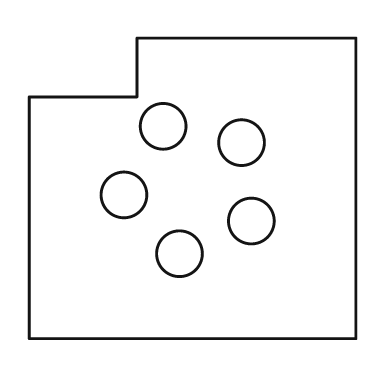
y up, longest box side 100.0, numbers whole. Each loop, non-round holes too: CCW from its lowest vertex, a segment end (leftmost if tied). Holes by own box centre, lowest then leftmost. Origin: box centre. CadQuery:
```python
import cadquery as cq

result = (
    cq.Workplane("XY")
    .moveTo(-50.0, -46.0)
    .lineTo(50.0, -46.0)
    .lineTo(50.0, 46.0)
    .lineTo(-17.0, 46.0)
    .lineTo(-17.0, 28.0)
    .lineTo(-50.0, 28.0)
    .close()
    .moveTo(-4.0, -20.0)
    .circle(7.0)
    .moveTo(18.0, -10.0)
    .circle(7.0)
    .moveTo(-21.0, -2.0)
    .circle(7.0)
    .moveTo(15.0, 14.0)
    .circle(7.0)
    .moveTo(-9.0, 19.0)
    .circle(7.0)
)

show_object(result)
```